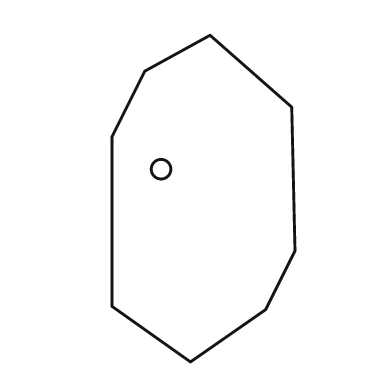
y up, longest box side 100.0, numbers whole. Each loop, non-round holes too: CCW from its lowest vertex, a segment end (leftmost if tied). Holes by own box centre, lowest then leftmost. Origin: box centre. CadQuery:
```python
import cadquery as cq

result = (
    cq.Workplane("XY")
    .moveTo(-4.0, -50.0)
    .lineTo(19.0, -34.0)
    .lineTo(28.0, -16.0)
    .lineTo(27.0, 28.0)
    .lineTo(2.0, 50.0)
    .lineTo(-18.0, 39.0)
    .lineTo(-28.0, 19.0)
    .lineTo(-28.0, -33.0)
    .close()
    .moveTo(-13.0, 9.0)
    .circle(3.0)
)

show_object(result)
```